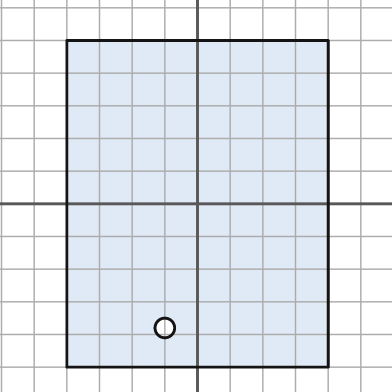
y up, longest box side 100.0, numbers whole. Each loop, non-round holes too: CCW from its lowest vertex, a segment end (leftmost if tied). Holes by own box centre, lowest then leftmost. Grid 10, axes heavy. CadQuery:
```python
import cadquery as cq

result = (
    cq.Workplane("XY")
    .moveTo(-40.0, -50.0)
    .lineTo(40.0, -50.0)
    .lineTo(40.0, 50.0)
    .lineTo(-40.0, 50.0)
    .close()
    .moveTo(-10.0, -38.0)
    .circle(3.0)
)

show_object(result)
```